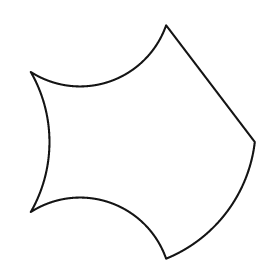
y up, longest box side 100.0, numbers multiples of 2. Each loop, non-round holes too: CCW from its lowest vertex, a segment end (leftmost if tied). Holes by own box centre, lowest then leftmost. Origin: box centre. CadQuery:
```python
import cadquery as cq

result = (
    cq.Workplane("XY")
    .moveTo(10.0, -50.0)
    .threePointArc((36.0, -30.0), (48.0, 0.0))
    .lineTo(10.0, 50.0)
    .threePointArc((-14.0, 26.0), (-48.0, 30.0))
    .threePointArc((-40.0, 0.0), (-48.0, -30.0))
    .threePointArc((-14.0, -26.0), (10.0, -50.0))
    .close()
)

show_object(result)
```